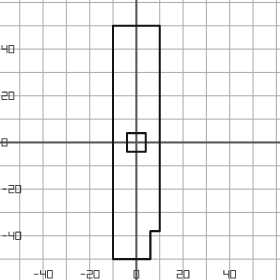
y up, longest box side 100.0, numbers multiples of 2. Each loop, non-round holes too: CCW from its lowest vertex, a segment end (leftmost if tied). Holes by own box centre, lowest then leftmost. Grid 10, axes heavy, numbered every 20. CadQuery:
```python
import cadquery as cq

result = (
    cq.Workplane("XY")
    .moveTo(-10.0, -50.0)
    .lineTo(6.0, -50.0)
    .lineTo(6.0, -38.0)
    .lineTo(10.0, -38.0)
    .lineTo(10.0, 50.0)
    .lineTo(-10.0, 50.0)
    .close()
    .moveTo(-4.0, -4.0)
    .lineTo(4.0, -4.0)
    .lineTo(4.0, 4.0)
    .lineTo(-4.0, 4.0)
    .close()
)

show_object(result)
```